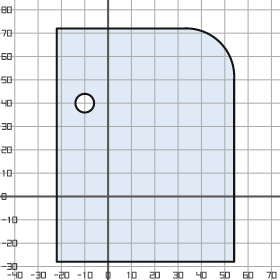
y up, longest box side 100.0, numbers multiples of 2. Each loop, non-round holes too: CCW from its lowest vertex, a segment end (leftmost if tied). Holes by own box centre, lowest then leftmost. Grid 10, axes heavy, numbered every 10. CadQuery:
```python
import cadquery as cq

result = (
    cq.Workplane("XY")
    .moveTo(-22.0, -28.0)
    .lineTo(54.0, -28.0)
    .lineTo(54.0, 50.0)
    .threePointArc((48.0, 66.0), (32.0, 72.0))
    .lineTo(-22.0, 72.0)
    .close()
    .moveTo(-10.0, 40.0)
    .circle(4.0)
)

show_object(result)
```